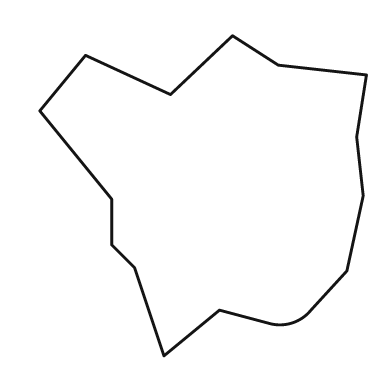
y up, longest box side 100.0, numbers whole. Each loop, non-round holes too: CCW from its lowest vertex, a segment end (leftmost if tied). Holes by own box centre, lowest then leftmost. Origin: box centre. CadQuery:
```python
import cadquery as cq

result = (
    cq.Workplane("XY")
    .moveTo(-12.0, -49.0)
    .lineTo(5.0, -35.0)
    .lineTo(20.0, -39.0)
    .threePointArc((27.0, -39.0), (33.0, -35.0))
    .lineTo(44.0, -23.0)
    .lineTo(49.0, 0.0)
    .lineTo(47.0, 18.0)
    .lineTo(50.0, 37.0)
    .lineTo(23.0, 40.0)
    .lineTo(9.0, 49.0)
    .lineTo(-10.0, 31.0)
    .lineTo(-36.0, 43.0)
    .lineTo(-50.0, 26.0)
    .lineTo(-28.0, -1.0)
    .lineTo(-28.0, -15.0)
    .lineTo(-21.0, -22.0)
    .close()
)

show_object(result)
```